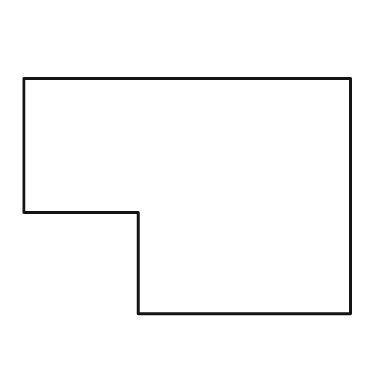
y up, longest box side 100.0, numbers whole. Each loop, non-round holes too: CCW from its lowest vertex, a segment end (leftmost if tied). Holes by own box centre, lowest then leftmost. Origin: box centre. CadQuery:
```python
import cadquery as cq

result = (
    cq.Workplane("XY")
    .moveTo(-15.0, -36.0)
    .lineTo(50.0, -36.0)
    .lineTo(50.0, 36.0)
    .lineTo(-50.0, 36.0)
    .lineTo(-50.0, -5.0)
    .lineTo(-15.0, -5.0)
    .close()
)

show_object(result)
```